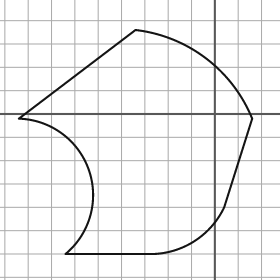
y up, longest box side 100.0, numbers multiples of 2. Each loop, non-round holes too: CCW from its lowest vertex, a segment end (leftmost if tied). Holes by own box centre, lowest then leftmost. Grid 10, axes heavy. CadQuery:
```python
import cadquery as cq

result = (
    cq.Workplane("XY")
    .moveTo(-64.0, -60.0)
    .lineTo(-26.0, -60.0)
    .threePointArc((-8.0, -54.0), (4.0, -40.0))
    .lineTo(16.0, -2.0)
    .threePointArc((-4.0, 24.0), (-34.0, 36.0))
    .lineTo(-84.0, -2.0)
    .threePointArc((-54.0, -24.0), (-64.0, -60.0))
    .close()
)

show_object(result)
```